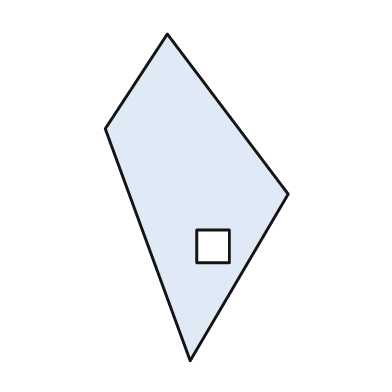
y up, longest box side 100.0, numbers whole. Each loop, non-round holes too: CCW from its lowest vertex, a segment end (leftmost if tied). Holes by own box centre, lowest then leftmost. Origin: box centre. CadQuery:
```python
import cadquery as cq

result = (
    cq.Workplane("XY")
    .moveTo(-2.0, -50.0)
    .lineTo(28.0, 1.0)
    .lineTo(-9.0, 50.0)
    .lineTo(-28.0, 21.0)
    .close()
    .moveTo(0.0, -20.0)
    .lineTo(10.0, -20.0)
    .lineTo(10.0, -10.0)
    .lineTo(0.0, -10.0)
    .close()
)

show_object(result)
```